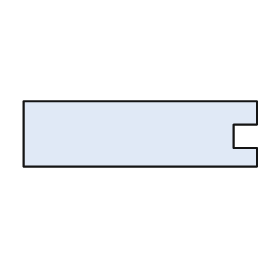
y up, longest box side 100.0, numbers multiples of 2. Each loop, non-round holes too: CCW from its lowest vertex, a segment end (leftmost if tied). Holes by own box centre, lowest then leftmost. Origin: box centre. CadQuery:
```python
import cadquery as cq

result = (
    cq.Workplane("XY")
    .moveTo(-50.0, -14.0)
    .lineTo(50.0, -14.0)
    .lineTo(50.0, -6.0)
    .lineTo(40.0, -6.0)
    .lineTo(40.0, 4.0)
    .lineTo(50.0, 4.0)
    .lineTo(50.0, 14.0)
    .lineTo(-50.0, 14.0)
    .close()
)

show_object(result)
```